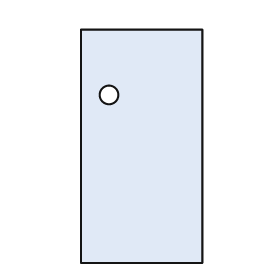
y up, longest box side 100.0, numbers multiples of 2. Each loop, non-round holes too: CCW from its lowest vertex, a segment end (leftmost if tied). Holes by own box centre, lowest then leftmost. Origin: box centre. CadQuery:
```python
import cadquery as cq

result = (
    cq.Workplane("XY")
    .moveTo(-26.0, -50.0)
    .lineTo(26.0, -50.0)
    .lineTo(26.0, 50.0)
    .lineTo(-26.0, 50.0)
    .close()
    .moveTo(-14.0, 22.0)
    .circle(4.0)
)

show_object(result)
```